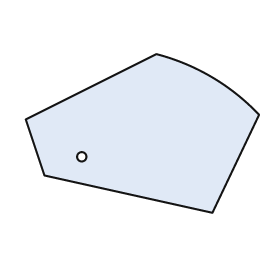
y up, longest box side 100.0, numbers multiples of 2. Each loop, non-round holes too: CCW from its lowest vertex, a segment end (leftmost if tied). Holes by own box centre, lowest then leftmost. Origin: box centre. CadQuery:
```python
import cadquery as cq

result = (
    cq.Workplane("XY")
    .moveTo(30.0, -34.0)
    .lineTo(50.0, 8.0)
    .threePointArc((30.0, 24.0), (6.0, 34.0))
    .lineTo(-50.0, 6.0)
    .lineTo(-42.0, -18.0)
    .close()
    .moveTo(-26.0, -10.0)
    .circle(2.0)
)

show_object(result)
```